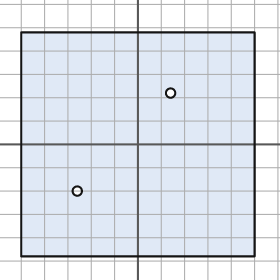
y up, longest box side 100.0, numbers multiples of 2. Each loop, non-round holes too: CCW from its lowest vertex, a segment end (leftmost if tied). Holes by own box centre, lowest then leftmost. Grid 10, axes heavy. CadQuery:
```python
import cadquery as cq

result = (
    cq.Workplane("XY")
    .moveTo(-50.0, -48.0)
    .lineTo(50.0, -48.0)
    .lineTo(50.0, 48.0)
    .lineTo(-50.0, 48.0)
    .close()
    .moveTo(-26.0, -20.0)
    .circle(2.0)
    .moveTo(14.0, 22.0)
    .circle(2.0)
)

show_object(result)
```